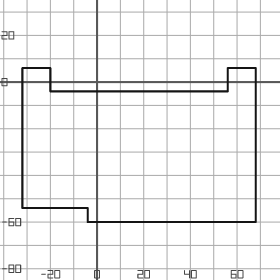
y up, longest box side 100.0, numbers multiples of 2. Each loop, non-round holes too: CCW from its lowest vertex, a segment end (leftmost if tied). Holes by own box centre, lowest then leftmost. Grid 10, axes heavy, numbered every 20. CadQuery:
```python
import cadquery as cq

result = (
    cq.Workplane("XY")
    .moveTo(-4.0, -60.0)
    .lineTo(68.0, -60.0)
    .lineTo(68.0, 6.0)
    .lineTo(56.0, 6.0)
    .lineTo(56.0, -4.0)
    .lineTo(-20.0, -4.0)
    .lineTo(-20.0, 6.0)
    .lineTo(-32.0, 6.0)
    .lineTo(-32.0, -54.0)
    .lineTo(-4.0, -54.0)
    .close()
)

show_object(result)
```